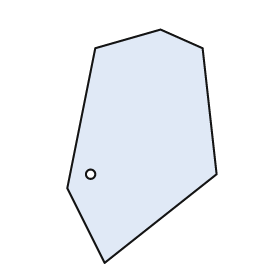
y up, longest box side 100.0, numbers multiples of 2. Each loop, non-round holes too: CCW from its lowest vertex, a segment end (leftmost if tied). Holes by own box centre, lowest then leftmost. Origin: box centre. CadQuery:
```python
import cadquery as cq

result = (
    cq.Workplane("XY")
    .moveTo(-16.0, -50.0)
    .lineTo(32.0, -12.0)
    .lineTo(26.0, 42.0)
    .lineTo(8.0, 50.0)
    .lineTo(-20.0, 42.0)
    .lineTo(-32.0, -18.0)
    .close()
    .moveTo(-22.0, -12.0)
    .circle(2.0)
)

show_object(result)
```